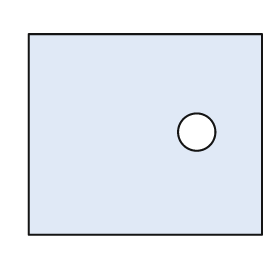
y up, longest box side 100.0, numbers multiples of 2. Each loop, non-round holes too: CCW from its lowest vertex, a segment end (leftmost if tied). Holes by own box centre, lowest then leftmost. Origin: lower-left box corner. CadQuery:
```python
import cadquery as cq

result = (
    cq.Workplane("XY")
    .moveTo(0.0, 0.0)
    .lineTo(100.0, 0.0)
    .lineTo(100.0, 86.0)
    .lineTo(0.0, 86.0)
    .close()
    .moveTo(72.0, 44.0)
    .circle(8.0)
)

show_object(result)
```